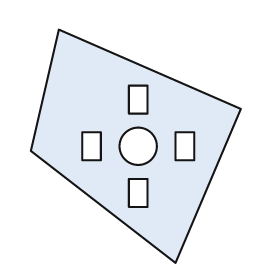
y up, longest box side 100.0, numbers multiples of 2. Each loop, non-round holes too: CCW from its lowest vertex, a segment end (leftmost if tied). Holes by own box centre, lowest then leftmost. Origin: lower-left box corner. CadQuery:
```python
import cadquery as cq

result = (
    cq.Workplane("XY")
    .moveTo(62.0, 0.0)
    .lineTo(90.0, 66.0)
    .lineTo(12.0, 100.0)
    .lineTo(0.0, 48.0)
    .close()
    .moveTo(42.0, 24.0)
    .lineTo(50.0, 24.0)
    .lineTo(50.0, 36.0)
    .lineTo(42.0, 36.0)
    .close()
    .moveTo(22.0, 44.0)
    .lineTo(30.0, 44.0)
    .lineTo(30.0, 56.0)
    .lineTo(22.0, 56.0)
    .close()
    .moveTo(46.0, 50.0)
    .circle(8.0)
    .moveTo(62.0, 44.0)
    .lineTo(70.0, 44.0)
    .lineTo(70.0, 56.0)
    .lineTo(62.0, 56.0)
    .close()
    .moveTo(42.0, 64.0)
    .lineTo(50.0, 64.0)
    .lineTo(50.0, 76.0)
    .lineTo(42.0, 76.0)
    .close()
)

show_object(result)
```